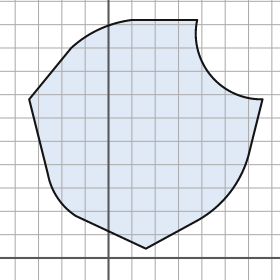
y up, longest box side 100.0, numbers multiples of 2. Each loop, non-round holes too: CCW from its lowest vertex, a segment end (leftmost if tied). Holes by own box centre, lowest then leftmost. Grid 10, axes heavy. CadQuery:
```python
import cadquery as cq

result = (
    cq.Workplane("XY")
    .moveTo(16.0, 4.0)
    .lineTo(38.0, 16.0)
    .threePointArc((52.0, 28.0), (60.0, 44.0))
    .lineTo(66.0, 68.0)
    .threePointArc((44.0, 78.0), (38.0, 102.0))
    .lineTo(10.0, 102.0)
    .threePointArc((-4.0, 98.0), (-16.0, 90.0))
    .lineTo(-34.0, 68.0)
    .lineTo(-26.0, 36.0)
    .threePointArc((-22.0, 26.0), (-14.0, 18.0))
    .close()
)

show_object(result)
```